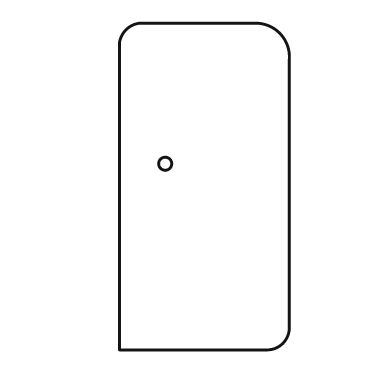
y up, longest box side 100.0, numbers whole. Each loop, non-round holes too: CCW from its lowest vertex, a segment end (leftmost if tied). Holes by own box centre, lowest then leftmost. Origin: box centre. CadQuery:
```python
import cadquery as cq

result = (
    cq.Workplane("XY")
    .moveTo(-26.0, -50.0)
    .lineTo(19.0, -50.0)
    .threePointArc((24.0, -48.0), (26.0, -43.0))
    .lineTo(26.0, 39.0)
    .threePointArc((23.0, 47.0), (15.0, 50.0))
    .lineTo(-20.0, 50.0)
    .threePointArc((-24.0, 48.0), (-26.0, 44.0))
    .close()
    .moveTo(-12.0, 7.0)
    .circle(2.0)
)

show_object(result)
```